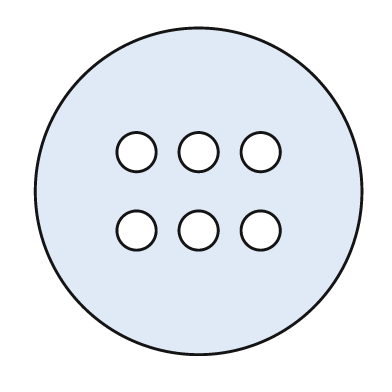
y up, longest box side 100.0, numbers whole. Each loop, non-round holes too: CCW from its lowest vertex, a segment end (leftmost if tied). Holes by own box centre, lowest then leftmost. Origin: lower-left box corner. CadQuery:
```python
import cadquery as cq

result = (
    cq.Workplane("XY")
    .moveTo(50.0, 50.0)
    .circle(50.0)
    .moveTo(31.0, 38.0)
    .circle(6.0)
    .moveTo(50.0, 38.0)
    .circle(6.0)
    .moveTo(69.0, 38.0)
    .circle(6.0)
    .moveTo(31.0, 62.0)
    .circle(6.0)
    .moveTo(50.0, 62.0)
    .circle(6.0)
    .moveTo(69.0, 62.0)
    .circle(6.0)
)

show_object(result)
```